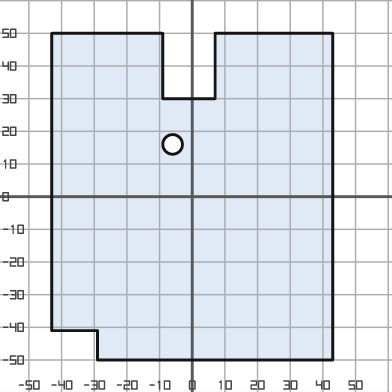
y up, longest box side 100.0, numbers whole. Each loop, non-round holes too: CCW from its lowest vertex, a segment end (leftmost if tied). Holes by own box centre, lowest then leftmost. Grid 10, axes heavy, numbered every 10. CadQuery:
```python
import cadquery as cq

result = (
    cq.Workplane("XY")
    .moveTo(-29.0, -50.0)
    .lineTo(43.0, -50.0)
    .lineTo(43.0, 50.0)
    .lineTo(7.0, 50.0)
    .lineTo(7.0, 30.0)
    .lineTo(-9.0, 30.0)
    .lineTo(-9.0, 50.0)
    .lineTo(-43.0, 50.0)
    .lineTo(-43.0, -41.0)
    .lineTo(-29.0, -41.0)
    .close()
    .moveTo(-6.0, 16.0)
    .circle(3.0)
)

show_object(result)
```